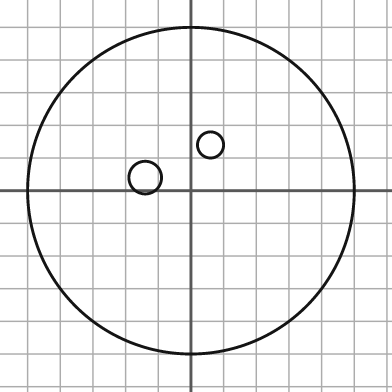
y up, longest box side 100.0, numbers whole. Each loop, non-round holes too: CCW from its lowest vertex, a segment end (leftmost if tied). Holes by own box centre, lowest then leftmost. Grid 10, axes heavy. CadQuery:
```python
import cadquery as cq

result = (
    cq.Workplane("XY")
    .moveTo(0.0, 0.0)
    .circle(50.0)
    .moveTo(-14.0, 4.0)
    .circle(5.0)
    .moveTo(6.0, 14.0)
    .circle(4.0)
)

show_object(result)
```